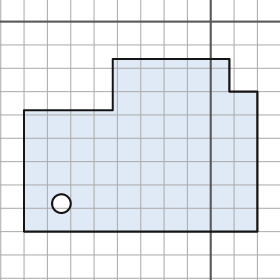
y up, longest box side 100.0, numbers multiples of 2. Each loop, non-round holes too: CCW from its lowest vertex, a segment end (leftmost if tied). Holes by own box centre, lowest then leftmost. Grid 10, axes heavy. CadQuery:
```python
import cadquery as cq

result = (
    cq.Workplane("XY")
    .moveTo(-80.0, -90.0)
    .lineTo(20.0, -90.0)
    .lineTo(20.0, -30.0)
    .lineTo(8.0, -30.0)
    .lineTo(8.0, -16.0)
    .lineTo(-42.0, -16.0)
    .lineTo(-42.0, -38.0)
    .lineTo(-80.0, -38.0)
    .close()
    .moveTo(-64.0, -78.0)
    .circle(4.0)
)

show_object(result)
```